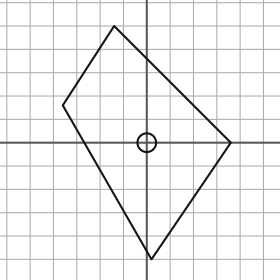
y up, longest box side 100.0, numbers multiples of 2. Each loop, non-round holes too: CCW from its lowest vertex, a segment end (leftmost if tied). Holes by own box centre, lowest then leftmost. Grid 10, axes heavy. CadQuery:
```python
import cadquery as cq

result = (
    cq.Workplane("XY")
    .moveTo(2.0, -50.0)
    .lineTo(36.0, 0.0)
    .lineTo(-14.0, 50.0)
    .lineTo(-36.0, 16.0)
    .close()
    .moveTo(0.0, 0.0)
    .circle(4.0)
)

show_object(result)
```